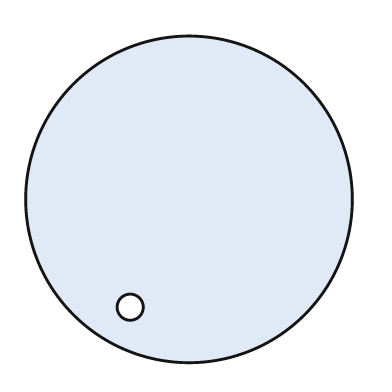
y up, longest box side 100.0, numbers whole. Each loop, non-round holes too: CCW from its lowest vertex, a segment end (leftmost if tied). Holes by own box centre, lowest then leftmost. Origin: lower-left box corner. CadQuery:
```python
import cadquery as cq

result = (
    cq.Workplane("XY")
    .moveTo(50.0, 50.0)
    .circle(50.0)
    .moveTo(32.0, 17.0)
    .circle(4.0)
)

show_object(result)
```